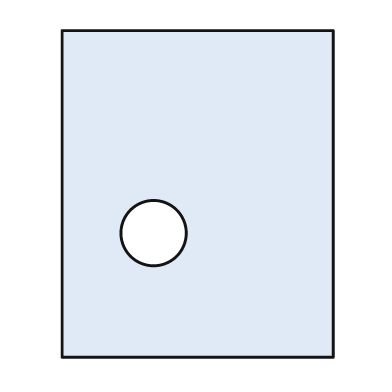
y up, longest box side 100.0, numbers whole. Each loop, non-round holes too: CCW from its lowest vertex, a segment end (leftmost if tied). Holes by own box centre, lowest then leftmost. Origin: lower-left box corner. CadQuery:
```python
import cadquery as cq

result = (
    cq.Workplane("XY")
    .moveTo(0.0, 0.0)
    .lineTo(83.0, 0.0)
    .lineTo(83.0, 100.0)
    .lineTo(0.0, 100.0)
    .close()
    .moveTo(28.0, 38.0)
    .circle(10.0)
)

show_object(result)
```